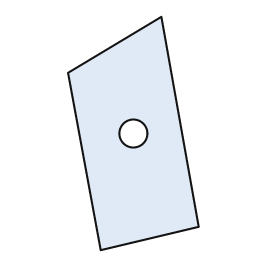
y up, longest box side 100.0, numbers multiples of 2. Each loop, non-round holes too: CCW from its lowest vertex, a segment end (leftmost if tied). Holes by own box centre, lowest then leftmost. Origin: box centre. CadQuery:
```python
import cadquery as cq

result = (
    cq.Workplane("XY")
    .moveTo(-14.0, -50.0)
    .lineTo(28.0, -40.0)
    .lineTo(12.0, 50.0)
    .lineTo(-28.0, 26.0)
    .close()
    .moveTo(0.0, 0.0)
    .circle(6.0)
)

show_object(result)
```